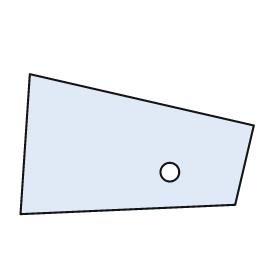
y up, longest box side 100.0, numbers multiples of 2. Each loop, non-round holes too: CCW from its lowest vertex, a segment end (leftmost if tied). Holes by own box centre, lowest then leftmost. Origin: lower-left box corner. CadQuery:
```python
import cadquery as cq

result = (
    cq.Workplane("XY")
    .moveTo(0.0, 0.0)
    .lineTo(92.0, 4.0)
    .lineTo(100.0, 38.0)
    .lineTo(4.0, 60.0)
    .close()
    .moveTo(64.0, 18.0)
    .circle(4.0)
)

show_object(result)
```